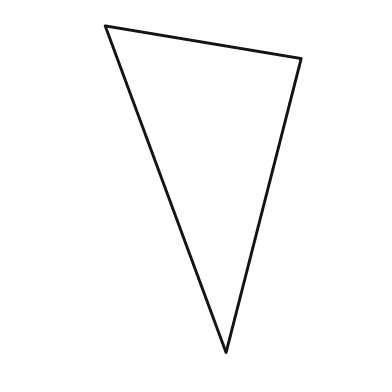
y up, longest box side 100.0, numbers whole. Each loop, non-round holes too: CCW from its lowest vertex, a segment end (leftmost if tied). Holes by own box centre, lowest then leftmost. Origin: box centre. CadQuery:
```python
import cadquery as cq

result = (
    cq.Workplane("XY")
    .moveTo(7.0, -50.0)
    .lineTo(30.0, 40.0)
    .lineTo(-30.0, 50.0)
    .close()
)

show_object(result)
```